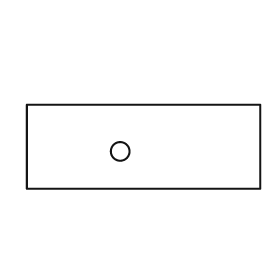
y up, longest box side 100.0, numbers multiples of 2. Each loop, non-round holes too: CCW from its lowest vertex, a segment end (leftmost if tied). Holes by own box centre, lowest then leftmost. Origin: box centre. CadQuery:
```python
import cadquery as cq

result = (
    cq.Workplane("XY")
    .moveTo(-50.0, -18.0)
    .lineTo(50.0, -18.0)
    .lineTo(50.0, 18.0)
    .lineTo(-50.0, 18.0)
    .close()
    .moveTo(-10.0, -2.0)
    .circle(4.0)
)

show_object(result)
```